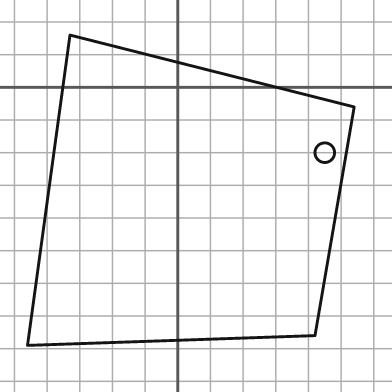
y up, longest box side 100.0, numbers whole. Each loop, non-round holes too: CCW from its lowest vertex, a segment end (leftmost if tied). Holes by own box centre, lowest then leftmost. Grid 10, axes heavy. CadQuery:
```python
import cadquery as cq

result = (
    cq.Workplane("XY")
    .moveTo(-46.0, -79.0)
    .lineTo(42.0, -76.0)
    .lineTo(54.0, -6.0)
    .lineTo(-33.0, 16.0)
    .close()
    .moveTo(45.0, -20.0)
    .circle(3.0)
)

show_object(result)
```